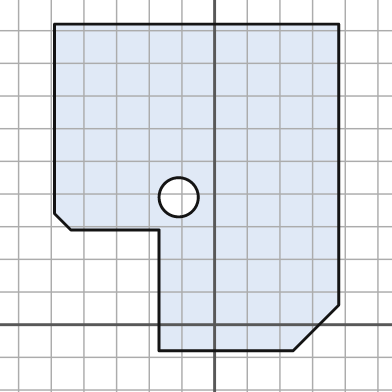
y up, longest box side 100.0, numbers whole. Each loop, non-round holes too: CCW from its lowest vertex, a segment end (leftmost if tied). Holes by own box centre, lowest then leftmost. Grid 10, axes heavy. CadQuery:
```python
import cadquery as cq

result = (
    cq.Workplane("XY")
    .moveTo(-17.0, -8.0)
    .lineTo(24.0, -8.0)
    .lineTo(38.0, 6.0)
    .lineTo(38.0, 92.0)
    .lineTo(-49.0, 92.0)
    .lineTo(-49.0, 34.0)
    .lineTo(-44.0, 29.0)
    .lineTo(-17.0, 29.0)
    .close()
    .moveTo(-11.0, 39.0)
    .circle(6.0)
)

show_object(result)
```